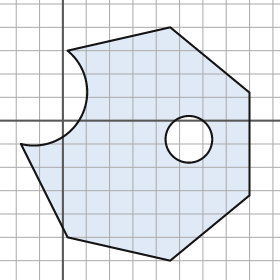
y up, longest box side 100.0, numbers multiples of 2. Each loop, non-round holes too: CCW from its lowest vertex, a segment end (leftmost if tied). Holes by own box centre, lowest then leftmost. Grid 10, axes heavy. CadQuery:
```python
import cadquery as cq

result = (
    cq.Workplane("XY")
    .moveTo(46.0, -60.0)
    .lineTo(80.0, -32.0)
    .lineTo(80.0, 12.0)
    .lineTo(46.0, 40.0)
    .lineTo(2.0, 30.0)
    .threePointArc((8.0, 2.0), (-18.0, -10.0))
    .lineTo(2.0, -50.0)
    .close()
    .moveTo(54.0, -8.0)
    .circle(10.0)
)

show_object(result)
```